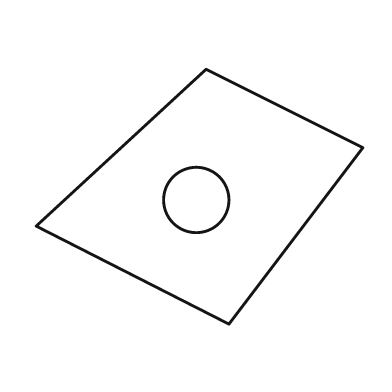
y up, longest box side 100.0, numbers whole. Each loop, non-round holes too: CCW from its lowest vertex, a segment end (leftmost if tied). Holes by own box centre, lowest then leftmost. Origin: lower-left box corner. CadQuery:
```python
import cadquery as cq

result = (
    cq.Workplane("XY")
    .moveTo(59.0, 0.0)
    .lineTo(100.0, 54.0)
    .lineTo(52.0, 78.0)
    .lineTo(0.0, 30.0)
    .close()
    .moveTo(49.0, 38.0)
    .circle(10.0)
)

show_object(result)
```